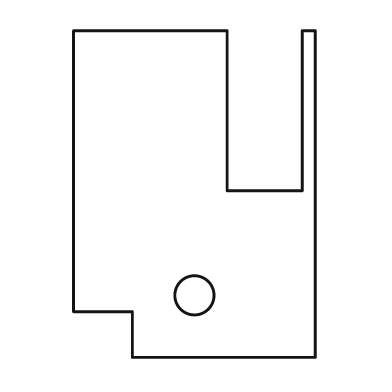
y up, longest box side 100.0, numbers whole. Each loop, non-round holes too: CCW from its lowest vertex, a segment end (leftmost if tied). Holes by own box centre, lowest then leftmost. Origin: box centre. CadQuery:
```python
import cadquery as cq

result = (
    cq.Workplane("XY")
    .moveTo(-19.0, -50.0)
    .lineTo(37.0, -50.0)
    .lineTo(37.0, 50.0)
    .lineTo(33.0, 50.0)
    .lineTo(33.0, 1.0)
    .lineTo(10.0, 1.0)
    .lineTo(10.0, 50.0)
    .lineTo(-37.0, 50.0)
    .lineTo(-37.0, -36.0)
    .lineTo(-19.0, -36.0)
    .close()
    .moveTo(0.0, -31.0)
    .circle(6.0)
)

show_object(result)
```